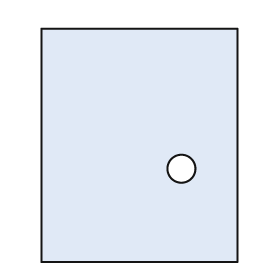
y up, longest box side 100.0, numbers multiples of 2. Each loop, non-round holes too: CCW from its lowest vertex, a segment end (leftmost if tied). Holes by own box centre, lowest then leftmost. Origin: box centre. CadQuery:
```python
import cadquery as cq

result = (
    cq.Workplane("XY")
    .moveTo(-42.0, -50.0)
    .lineTo(42.0, -50.0)
    .lineTo(42.0, 50.0)
    .lineTo(-42.0, 50.0)
    .close()
    .moveTo(18.0, -10.0)
    .circle(6.0)
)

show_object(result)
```